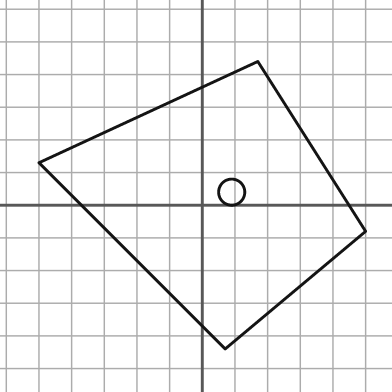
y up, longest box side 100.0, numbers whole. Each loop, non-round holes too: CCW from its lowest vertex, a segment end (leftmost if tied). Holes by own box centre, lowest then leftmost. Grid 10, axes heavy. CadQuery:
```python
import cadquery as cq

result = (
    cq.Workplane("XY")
    .moveTo(7.0, -44.0)
    .lineTo(50.0, -8.0)
    .lineTo(17.0, 44.0)
    .lineTo(-50.0, 13.0)
    .close()
    .moveTo(9.0, 4.0)
    .circle(4.0)
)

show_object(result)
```